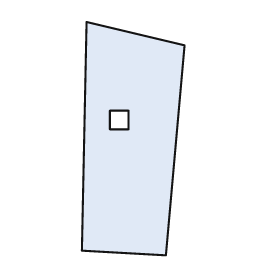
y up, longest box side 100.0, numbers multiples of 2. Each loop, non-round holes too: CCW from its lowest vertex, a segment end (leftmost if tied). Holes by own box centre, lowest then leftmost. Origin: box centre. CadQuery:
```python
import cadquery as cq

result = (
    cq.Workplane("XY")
    .moveTo(14.0, -50.0)
    .lineTo(22.0, 40.0)
    .lineTo(-20.0, 50.0)
    .lineTo(-22.0, -48.0)
    .close()
    .moveTo(-10.0, 4.0)
    .lineTo(-2.0, 4.0)
    .lineTo(-2.0, 12.0)
    .lineTo(-10.0, 12.0)
    .close()
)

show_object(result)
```